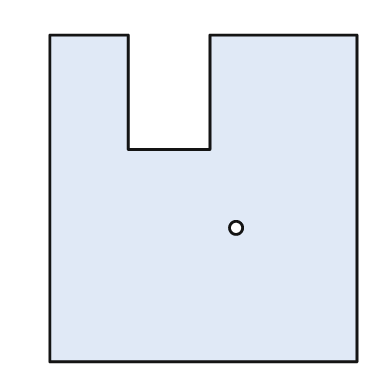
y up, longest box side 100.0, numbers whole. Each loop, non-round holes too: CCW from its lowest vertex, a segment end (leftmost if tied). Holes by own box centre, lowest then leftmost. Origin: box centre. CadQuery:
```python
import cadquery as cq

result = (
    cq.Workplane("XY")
    .moveTo(-47.0, -50.0)
    .lineTo(47.0, -50.0)
    .lineTo(47.0, 50.0)
    .lineTo(2.0, 50.0)
    .lineTo(2.0, 15.0)
    .lineTo(-23.0, 15.0)
    .lineTo(-23.0, 50.0)
    .lineTo(-47.0, 50.0)
    .close()
    .moveTo(10.0, -9.0)
    .circle(2.0)
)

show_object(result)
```